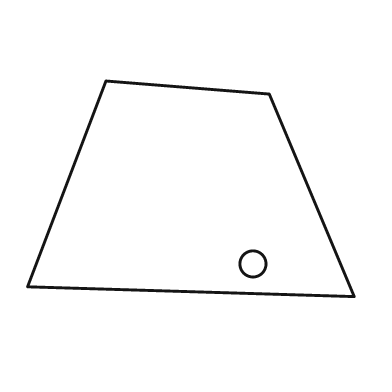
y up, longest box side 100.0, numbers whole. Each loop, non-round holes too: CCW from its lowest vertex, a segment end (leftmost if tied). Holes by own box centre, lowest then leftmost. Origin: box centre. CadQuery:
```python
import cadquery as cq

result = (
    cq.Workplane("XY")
    .moveTo(50.0, -33.0)
    .lineTo(24.0, 29.0)
    .lineTo(-26.0, 33.0)
    .lineTo(-50.0, -30.0)
    .close()
    .moveTo(19.0, -23.0)
    .circle(4.0)
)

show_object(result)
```